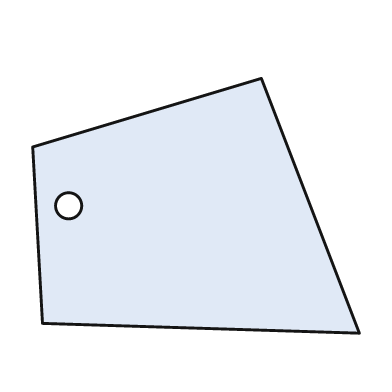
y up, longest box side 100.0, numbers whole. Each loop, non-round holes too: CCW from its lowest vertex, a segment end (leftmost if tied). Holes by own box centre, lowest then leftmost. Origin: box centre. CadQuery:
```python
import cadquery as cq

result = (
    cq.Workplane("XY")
    .moveTo(50.0, -39.0)
    .lineTo(20.0, 39.0)
    .lineTo(-50.0, 18.0)
    .lineTo(-47.0, -36.0)
    .close()
    .moveTo(-39.0, 0.0)
    .circle(4.0)
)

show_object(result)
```